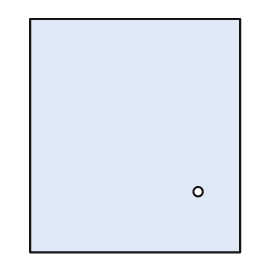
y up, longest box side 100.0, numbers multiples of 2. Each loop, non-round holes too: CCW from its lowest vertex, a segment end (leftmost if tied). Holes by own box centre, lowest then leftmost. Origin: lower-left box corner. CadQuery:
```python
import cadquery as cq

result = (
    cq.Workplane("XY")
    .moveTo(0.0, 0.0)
    .lineTo(90.0, 0.0)
    .lineTo(90.0, 100.0)
    .lineTo(0.0, 100.0)
    .close()
    .moveTo(72.0, 26.0)
    .circle(2.0)
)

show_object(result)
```